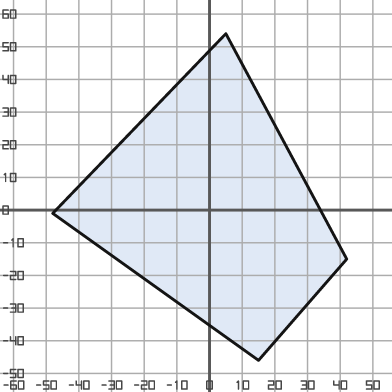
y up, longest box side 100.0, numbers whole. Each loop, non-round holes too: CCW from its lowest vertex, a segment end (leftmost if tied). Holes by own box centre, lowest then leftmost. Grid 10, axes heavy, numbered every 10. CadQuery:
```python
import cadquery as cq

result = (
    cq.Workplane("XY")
    .moveTo(15.0, -46.0)
    .lineTo(42.0, -15.0)
    .lineTo(5.0, 54.0)
    .lineTo(-48.0, -1.0)
    .close()
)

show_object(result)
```